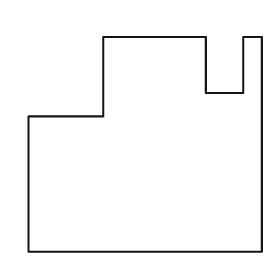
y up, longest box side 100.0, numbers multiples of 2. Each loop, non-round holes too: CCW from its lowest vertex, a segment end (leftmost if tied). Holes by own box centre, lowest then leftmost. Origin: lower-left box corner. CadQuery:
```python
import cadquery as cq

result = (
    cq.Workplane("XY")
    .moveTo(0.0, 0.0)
    .lineTo(100.0, 0.0)
    .lineTo(100.0, 92.0)
    .lineTo(92.0, 92.0)
    .lineTo(92.0, 68.0)
    .lineTo(76.0, 68.0)
    .lineTo(76.0, 92.0)
    .lineTo(32.0, 92.0)
    .lineTo(32.0, 58.0)
    .lineTo(0.0, 58.0)
    .close()
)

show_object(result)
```